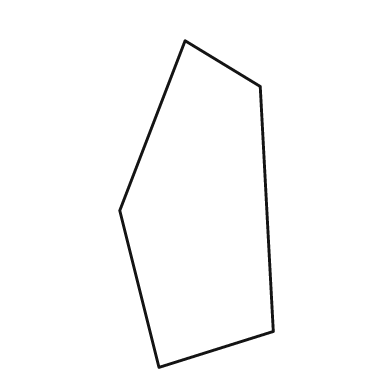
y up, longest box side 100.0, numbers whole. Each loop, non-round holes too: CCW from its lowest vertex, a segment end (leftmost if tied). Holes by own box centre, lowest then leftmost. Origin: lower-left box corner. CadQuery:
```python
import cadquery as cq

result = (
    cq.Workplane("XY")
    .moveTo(12.0, 0.0)
    .lineTo(47.0, 11.0)
    .lineTo(43.0, 86.0)
    .lineTo(20.0, 100.0)
    .lineTo(0.0, 48.0)
    .close()
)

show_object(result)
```